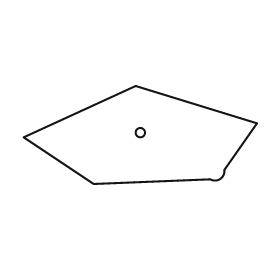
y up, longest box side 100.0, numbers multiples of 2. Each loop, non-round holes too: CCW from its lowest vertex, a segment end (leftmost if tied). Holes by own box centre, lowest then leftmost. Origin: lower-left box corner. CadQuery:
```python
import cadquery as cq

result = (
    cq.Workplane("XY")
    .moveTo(30.0, 0.0)
    .lineTo(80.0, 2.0)
    .threePointArc((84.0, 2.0), (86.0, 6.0))
    .lineTo(100.0, 26.0)
    .lineTo(48.0, 42.0)
    .lineTo(0.0, 20.0)
    .close()
    .moveTo(50.0, 22.0)
    .circle(2.0)
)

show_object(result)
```